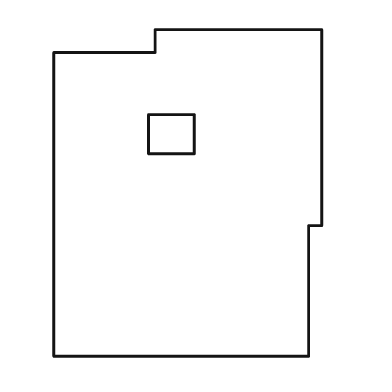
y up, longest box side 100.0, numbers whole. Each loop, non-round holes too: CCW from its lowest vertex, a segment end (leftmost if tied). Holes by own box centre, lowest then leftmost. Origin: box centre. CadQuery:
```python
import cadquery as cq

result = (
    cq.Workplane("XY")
    .moveTo(-41.0, -50.0)
    .lineTo(37.0, -50.0)
    .lineTo(37.0, -10.0)
    .lineTo(41.0, -10.0)
    .lineTo(41.0, 50.0)
    .lineTo(-10.0, 50.0)
    .lineTo(-10.0, 43.0)
    .lineTo(-41.0, 43.0)
    .close()
    .moveTo(-12.0, 12.0)
    .lineTo(2.0, 12.0)
    .lineTo(2.0, 24.0)
    .lineTo(-12.0, 24.0)
    .close()
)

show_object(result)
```